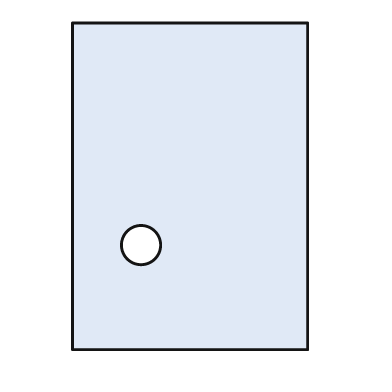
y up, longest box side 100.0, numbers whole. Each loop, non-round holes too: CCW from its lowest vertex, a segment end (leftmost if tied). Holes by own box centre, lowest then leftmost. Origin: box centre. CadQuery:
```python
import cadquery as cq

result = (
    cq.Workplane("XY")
    .moveTo(-36.0, -50.0)
    .lineTo(36.0, -50.0)
    .lineTo(36.0, 50.0)
    .lineTo(-36.0, 50.0)
    .close()
    .moveTo(-15.0, -18.0)
    .circle(6.0)
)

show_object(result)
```